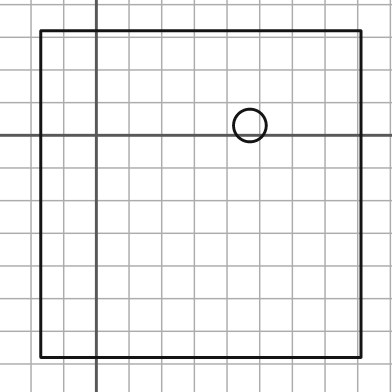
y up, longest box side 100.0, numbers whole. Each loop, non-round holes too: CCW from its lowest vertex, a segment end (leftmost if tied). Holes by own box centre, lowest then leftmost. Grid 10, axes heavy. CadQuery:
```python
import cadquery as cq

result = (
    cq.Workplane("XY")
    .moveTo(-17.0, -68.0)
    .lineTo(81.0, -68.0)
    .lineTo(81.0, 32.0)
    .lineTo(-17.0, 32.0)
    .close()
    .moveTo(47.0, 3.0)
    .circle(5.0)
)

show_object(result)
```